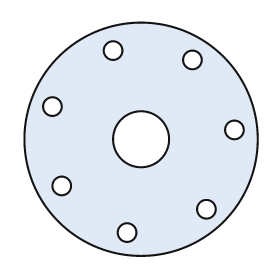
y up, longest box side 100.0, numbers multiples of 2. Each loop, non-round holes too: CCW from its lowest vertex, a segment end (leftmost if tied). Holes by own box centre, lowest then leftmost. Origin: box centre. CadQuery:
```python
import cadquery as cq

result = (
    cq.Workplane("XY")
    .moveTo(0.0, 0.0)
    .circle(50.0)
    .moveTo(-6.0, -40.0)
    .circle(4.0)
    .moveTo(28.0, -30.0)
    .circle(4.0)
    .moveTo(-34.0, -20.0)
    .circle(4.0)
    .moveTo(0.0, 0.0)
    .circle(12.0)
    .moveTo(40.0, 4.0)
    .circle(4.0)
    .moveTo(-38.0, 14.0)
    .circle(4.0)
    .moveTo(22.0, 34.0)
    .circle(4.0)
    .moveTo(-12.0, 38.0)
    .circle(4.0)
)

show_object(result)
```